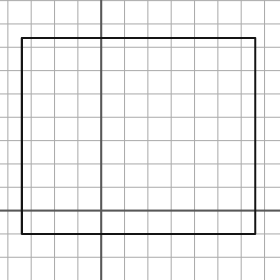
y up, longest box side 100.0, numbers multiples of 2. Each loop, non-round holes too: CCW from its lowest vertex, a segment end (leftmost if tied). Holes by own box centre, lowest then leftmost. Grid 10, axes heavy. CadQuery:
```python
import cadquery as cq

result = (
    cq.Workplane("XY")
    .moveTo(-34.0, -10.0)
    .lineTo(66.0, -10.0)
    .lineTo(66.0, 74.0)
    .lineTo(-34.0, 74.0)
    .close()
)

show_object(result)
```